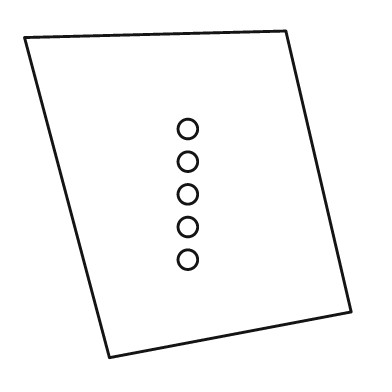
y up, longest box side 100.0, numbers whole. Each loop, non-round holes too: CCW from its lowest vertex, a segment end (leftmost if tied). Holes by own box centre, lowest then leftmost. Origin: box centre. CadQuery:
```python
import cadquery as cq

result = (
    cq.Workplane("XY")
    .moveTo(-24.0, -50.0)
    .lineTo(50.0, -36.0)
    .lineTo(30.0, 50.0)
    .lineTo(-50.0, 48.0)
    .close()
    .moveTo(0.0, -20.0)
    .circle(3.0)
    .moveTo(0.0, -10.0)
    .circle(3.0)
    .moveTo(0.0, 0.0)
    .circle(3.0)
    .moveTo(0.0, 10.0)
    .circle(3.0)
    .moveTo(0.0, 20.0)
    .circle(3.0)
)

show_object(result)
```